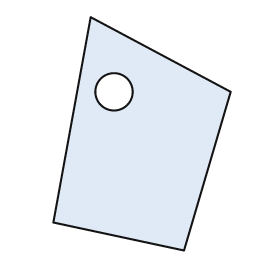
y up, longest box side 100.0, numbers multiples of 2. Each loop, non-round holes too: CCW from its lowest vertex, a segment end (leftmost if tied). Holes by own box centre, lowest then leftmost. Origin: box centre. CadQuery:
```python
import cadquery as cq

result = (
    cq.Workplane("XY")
    .moveTo(18.0, -50.0)
    .lineTo(38.0, 18.0)
    .lineTo(-22.0, 50.0)
    .lineTo(-38.0, -38.0)
    .close()
    .moveTo(-12.0, 18.0)
    .circle(8.0)
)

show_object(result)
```